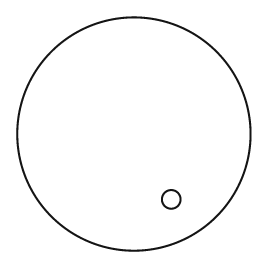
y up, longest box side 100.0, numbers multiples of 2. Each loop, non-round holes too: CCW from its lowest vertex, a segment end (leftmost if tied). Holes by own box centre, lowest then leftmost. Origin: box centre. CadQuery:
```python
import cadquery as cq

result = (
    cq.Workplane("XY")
    .moveTo(0.0, 0.0)
    .circle(50.0)
    .moveTo(16.0, -28.0)
    .circle(4.0)
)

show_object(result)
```